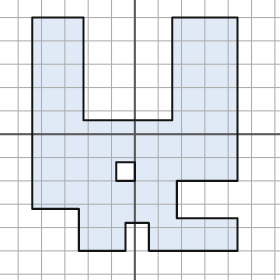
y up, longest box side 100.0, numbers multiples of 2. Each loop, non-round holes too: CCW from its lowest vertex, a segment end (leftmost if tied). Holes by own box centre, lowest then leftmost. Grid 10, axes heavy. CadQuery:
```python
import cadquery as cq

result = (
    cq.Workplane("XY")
    .moveTo(-24.0, -50.0)
    .lineTo(-4.0, -50.0)
    .lineTo(-4.0, -38.0)
    .lineTo(6.0, -38.0)
    .lineTo(6.0, -50.0)
    .lineTo(44.0, -50.0)
    .lineTo(44.0, -36.0)
    .lineTo(18.0, -36.0)
    .lineTo(18.0, -20.0)
    .lineTo(44.0, -20.0)
    .lineTo(44.0, 50.0)
    .lineTo(16.0, 50.0)
    .lineTo(16.0, 6.0)
    .lineTo(-22.0, 6.0)
    .lineTo(-22.0, 50.0)
    .lineTo(-44.0, 50.0)
    .lineTo(-44.0, -32.0)
    .lineTo(-24.0, -32.0)
    .close()
    .moveTo(-8.0, -20.0)
    .lineTo(0.0, -20.0)
    .lineTo(0.0, -12.0)
    .lineTo(-8.0, -12.0)
    .close()
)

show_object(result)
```